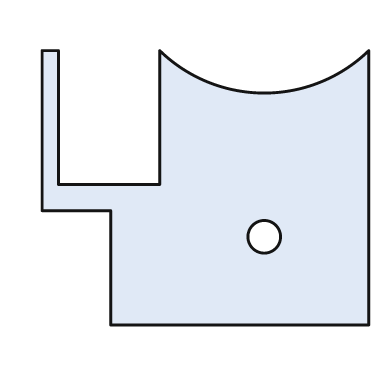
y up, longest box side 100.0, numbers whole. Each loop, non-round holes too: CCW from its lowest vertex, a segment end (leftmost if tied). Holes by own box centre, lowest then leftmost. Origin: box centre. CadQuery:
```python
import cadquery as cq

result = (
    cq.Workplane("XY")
    .moveTo(-29.0, -42.0)
    .lineTo(50.0, -42.0)
    .lineTo(50.0, 42.0)
    .threePointArc((18.0, 29.0), (-14.0, 42.0))
    .lineTo(-14.0, 1.0)
    .lineTo(-45.0, 1.0)
    .lineTo(-45.0, 42.0)
    .lineTo(-50.0, 42.0)
    .lineTo(-50.0, -7.0)
    .lineTo(-29.0, -7.0)
    .close()
    .moveTo(18.0, -15.0)
    .circle(5.0)
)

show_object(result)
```